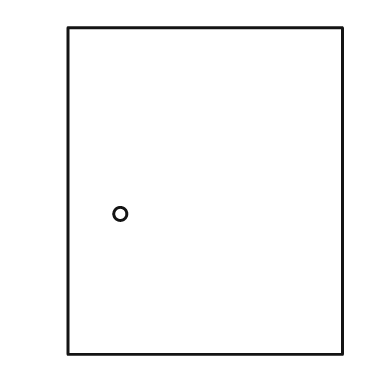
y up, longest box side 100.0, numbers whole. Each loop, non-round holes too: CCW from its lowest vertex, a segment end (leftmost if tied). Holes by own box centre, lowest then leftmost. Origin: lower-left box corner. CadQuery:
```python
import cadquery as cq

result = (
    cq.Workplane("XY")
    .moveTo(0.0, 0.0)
    .lineTo(84.0, 0.0)
    .lineTo(84.0, 100.0)
    .lineTo(0.0, 100.0)
    .close()
    .moveTo(16.0, 43.0)
    .circle(2.0)
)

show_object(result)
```